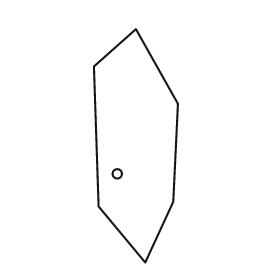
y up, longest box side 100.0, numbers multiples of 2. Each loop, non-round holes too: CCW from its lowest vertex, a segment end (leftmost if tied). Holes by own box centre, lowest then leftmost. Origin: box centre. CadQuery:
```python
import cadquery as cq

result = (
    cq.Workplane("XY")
    .moveTo(4.0, -50.0)
    .lineTo(16.0, -24.0)
    .lineTo(18.0, 18.0)
    .lineTo(0.0, 50.0)
    .lineTo(-18.0, 34.0)
    .lineTo(-16.0, -26.0)
    .close()
    .moveTo(-8.0, -12.0)
    .circle(2.0)
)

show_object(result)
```